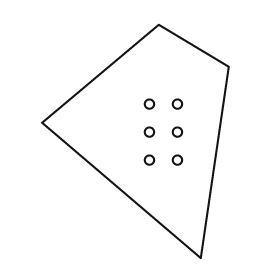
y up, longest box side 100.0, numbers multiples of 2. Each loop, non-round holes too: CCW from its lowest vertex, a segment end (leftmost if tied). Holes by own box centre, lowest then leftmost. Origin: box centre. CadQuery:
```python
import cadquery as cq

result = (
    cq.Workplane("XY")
    .moveTo(28.0, -50.0)
    .lineTo(40.0, 32.0)
    .lineTo(10.0, 50.0)
    .lineTo(-40.0, 8.0)
    .close()
    .moveTo(6.0, -8.0)
    .circle(2.0)
    .moveTo(18.0, -8.0)
    .circle(2.0)
    .moveTo(6.0, 4.0)
    .circle(2.0)
    .moveTo(18.0, 4.0)
    .circle(2.0)
    .moveTo(6.0, 16.0)
    .circle(2.0)
    .moveTo(18.0, 16.0)
    .circle(2.0)
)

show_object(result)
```